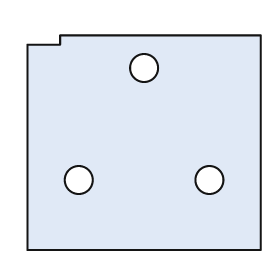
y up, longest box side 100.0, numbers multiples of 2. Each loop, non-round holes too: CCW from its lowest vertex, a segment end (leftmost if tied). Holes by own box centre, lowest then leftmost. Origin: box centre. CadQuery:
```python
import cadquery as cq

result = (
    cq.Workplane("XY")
    .moveTo(-50.0, -46.0)
    .lineTo(50.0, -46.0)
    .lineTo(50.0, 46.0)
    .lineTo(-36.0, 46.0)
    .lineTo(-36.0, 42.0)
    .lineTo(-50.0, 42.0)
    .close()
    .moveTo(-28.0, -16.0)
    .circle(6.0)
    .moveTo(28.0, -16.0)
    .circle(6.0)
    .moveTo(0.0, 32.0)
    .circle(6.0)
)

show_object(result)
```